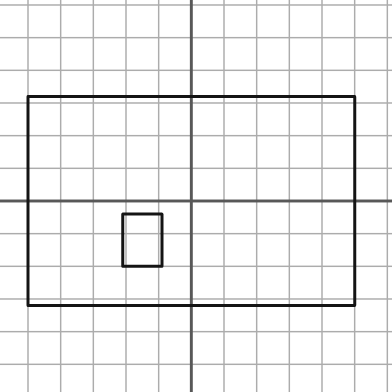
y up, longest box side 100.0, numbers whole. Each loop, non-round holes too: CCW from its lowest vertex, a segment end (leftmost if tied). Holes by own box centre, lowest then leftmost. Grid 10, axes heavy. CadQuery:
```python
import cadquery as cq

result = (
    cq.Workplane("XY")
    .moveTo(-50.0, -32.0)
    .lineTo(50.0, -32.0)
    .lineTo(50.0, 32.0)
    .lineTo(-50.0, 32.0)
    .close()
    .moveTo(-21.0, -20.0)
    .lineTo(-9.0, -20.0)
    .lineTo(-9.0, -4.0)
    .lineTo(-21.0, -4.0)
    .close()
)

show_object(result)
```